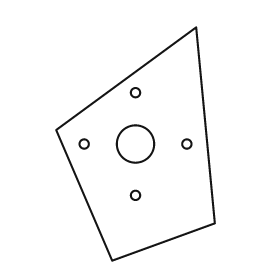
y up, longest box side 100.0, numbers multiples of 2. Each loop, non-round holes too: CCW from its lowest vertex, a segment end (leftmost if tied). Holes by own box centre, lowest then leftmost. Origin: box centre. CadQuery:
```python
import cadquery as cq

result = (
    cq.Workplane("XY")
    .moveTo(-10.0, -50.0)
    .lineTo(34.0, -34.0)
    .lineTo(26.0, 50.0)
    .lineTo(-34.0, 6.0)
    .close()
    .moveTo(0.0, -22.0)
    .circle(2.0)
    .moveTo(-22.0, 0.0)
    .circle(2.0)
    .moveTo(0.0, 0.0)
    .circle(8.0)
    .moveTo(22.0, 0.0)
    .circle(2.0)
    .moveTo(0.0, 22.0)
    .circle(2.0)
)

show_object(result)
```